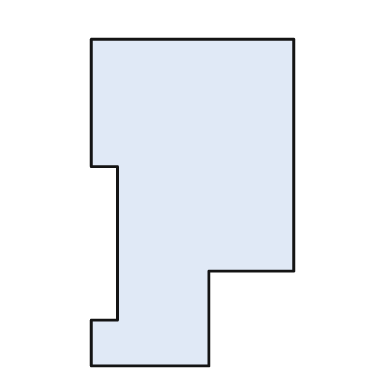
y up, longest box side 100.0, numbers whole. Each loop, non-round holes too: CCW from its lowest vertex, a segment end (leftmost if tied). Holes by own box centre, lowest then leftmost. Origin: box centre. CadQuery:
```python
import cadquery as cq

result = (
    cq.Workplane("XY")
    .moveTo(-31.0, -50.0)
    .lineTo(5.0, -50.0)
    .lineTo(5.0, -21.0)
    .lineTo(31.0, -21.0)
    .lineTo(31.0, 50.0)
    .lineTo(-31.0, 50.0)
    .lineTo(-31.0, 11.0)
    .lineTo(-23.0, 11.0)
    .lineTo(-23.0, -36.0)
    .lineTo(-31.0, -36.0)
    .close()
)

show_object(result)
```